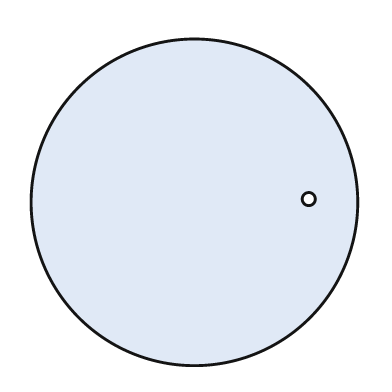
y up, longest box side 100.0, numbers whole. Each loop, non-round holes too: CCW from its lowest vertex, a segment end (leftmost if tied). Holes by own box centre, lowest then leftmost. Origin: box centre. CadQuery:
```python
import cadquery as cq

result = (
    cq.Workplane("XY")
    .moveTo(0.0, 0.0)
    .circle(50.0)
    .moveTo(35.0, 1.0)
    .circle(2.0)
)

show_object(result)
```